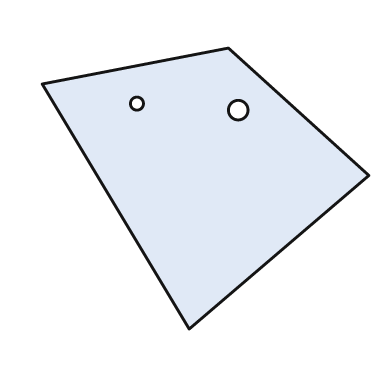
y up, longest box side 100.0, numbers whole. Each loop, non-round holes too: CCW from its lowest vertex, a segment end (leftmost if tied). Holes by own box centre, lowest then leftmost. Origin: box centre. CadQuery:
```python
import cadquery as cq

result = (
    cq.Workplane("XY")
    .moveTo(-5.0, -43.0)
    .lineTo(50.0, 4.0)
    .lineTo(7.0, 43.0)
    .lineTo(-50.0, 32.0)
    .close()
    .moveTo(10.0, 24.0)
    .circle(3.0)
    .moveTo(-21.0, 26.0)
    .circle(2.0)
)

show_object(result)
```